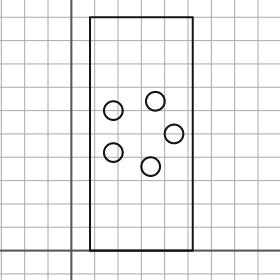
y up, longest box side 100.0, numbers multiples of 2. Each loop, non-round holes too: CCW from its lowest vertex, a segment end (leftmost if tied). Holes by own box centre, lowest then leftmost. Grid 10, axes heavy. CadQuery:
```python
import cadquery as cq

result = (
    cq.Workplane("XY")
    .moveTo(8.0, 0.0)
    .lineTo(52.0, 0.0)
    .lineTo(52.0, 100.0)
    .lineTo(8.0, 100.0)
    .close()
    .moveTo(34.0, 36.0)
    .circle(4.0)
    .moveTo(18.0, 42.0)
    .circle(4.0)
    .moveTo(44.0, 50.0)
    .circle(4.0)
    .moveTo(18.0, 60.0)
    .circle(4.0)
    .moveTo(36.0, 64.0)
    .circle(4.0)
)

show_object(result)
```